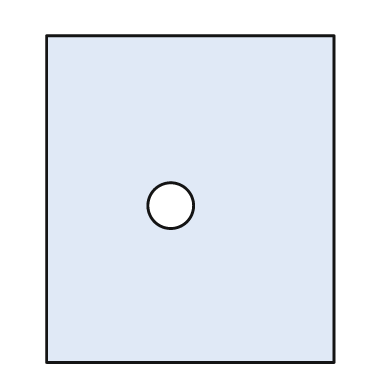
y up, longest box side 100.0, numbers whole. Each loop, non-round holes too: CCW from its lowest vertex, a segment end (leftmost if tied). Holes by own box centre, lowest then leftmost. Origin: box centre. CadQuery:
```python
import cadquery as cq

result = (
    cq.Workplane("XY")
    .moveTo(-44.0, -50.0)
    .lineTo(44.0, -50.0)
    .lineTo(44.0, 50.0)
    .lineTo(-44.0, 50.0)
    .close()
    .moveTo(-6.0, -2.0)
    .circle(7.0)
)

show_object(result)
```